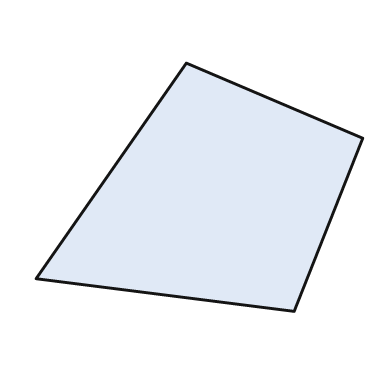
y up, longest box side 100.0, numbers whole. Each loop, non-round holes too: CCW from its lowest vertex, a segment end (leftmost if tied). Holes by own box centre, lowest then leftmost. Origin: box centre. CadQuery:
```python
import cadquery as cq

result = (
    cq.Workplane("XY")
    .moveTo(29.0, -38.0)
    .lineTo(50.0, 15.0)
    .lineTo(-4.0, 38.0)
    .lineTo(-50.0, -28.0)
    .close()
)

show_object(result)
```